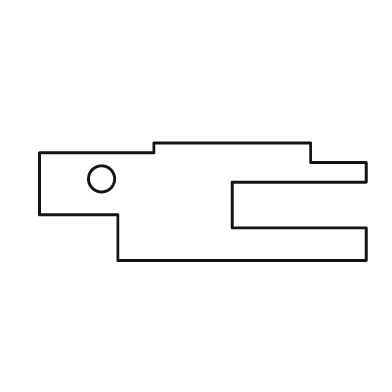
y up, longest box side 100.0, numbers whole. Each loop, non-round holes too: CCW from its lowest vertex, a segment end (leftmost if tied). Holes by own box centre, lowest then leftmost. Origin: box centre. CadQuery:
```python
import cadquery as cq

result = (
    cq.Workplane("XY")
    .moveTo(-26.0, -18.0)
    .lineTo(50.0, -18.0)
    .lineTo(50.0, -8.0)
    .lineTo(9.0, -8.0)
    .lineTo(9.0, 6.0)
    .lineTo(50.0, 6.0)
    .lineTo(50.0, 12.0)
    .lineTo(33.0, 12.0)
    .lineTo(33.0, 18.0)
    .lineTo(-15.0, 18.0)
    .lineTo(-15.0, 15.0)
    .lineTo(-50.0, 15.0)
    .lineTo(-50.0, -4.0)
    .lineTo(-26.0, -4.0)
    .close()
    .moveTo(-31.0, 7.0)
    .circle(4.0)
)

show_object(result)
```